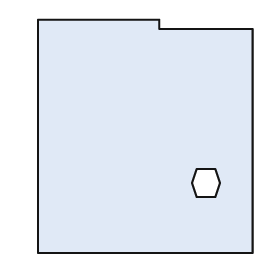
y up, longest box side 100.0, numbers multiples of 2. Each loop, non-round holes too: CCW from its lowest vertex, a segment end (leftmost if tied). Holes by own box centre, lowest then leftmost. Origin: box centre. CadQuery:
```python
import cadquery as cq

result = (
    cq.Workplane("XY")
    .moveTo(-46.0, -50.0)
    .lineTo(46.0, -50.0)
    .lineTo(46.0, 46.0)
    .lineTo(6.0, 46.0)
    .lineTo(6.0, 50.0)
    .lineTo(-46.0, 50.0)
    .close()
    .moveTo(22.0, -26.0)
    .lineTo(30.0, -26.0)
    .lineTo(32.0, -20.0)
    .lineTo(30.0, -14.0)
    .lineTo(22.0, -14.0)
    .lineTo(20.0, -20.0)
    .close()
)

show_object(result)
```